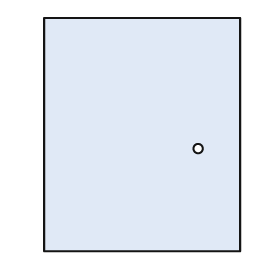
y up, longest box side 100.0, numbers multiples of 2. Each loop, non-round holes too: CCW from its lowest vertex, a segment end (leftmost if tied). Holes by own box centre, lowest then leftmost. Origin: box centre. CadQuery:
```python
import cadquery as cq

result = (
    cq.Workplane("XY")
    .moveTo(-42.0, -50.0)
    .lineTo(42.0, -50.0)
    .lineTo(42.0, 50.0)
    .lineTo(-42.0, 50.0)
    .close()
    .moveTo(24.0, -6.0)
    .circle(2.0)
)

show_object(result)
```